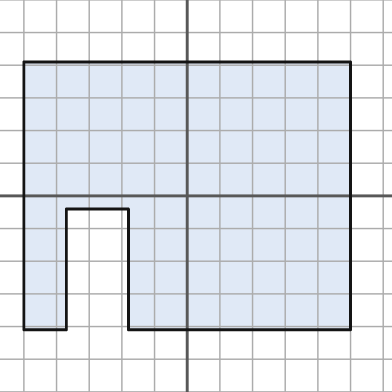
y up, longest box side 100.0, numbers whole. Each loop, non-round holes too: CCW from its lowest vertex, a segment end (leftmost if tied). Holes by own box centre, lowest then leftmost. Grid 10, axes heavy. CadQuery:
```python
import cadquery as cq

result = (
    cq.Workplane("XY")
    .moveTo(-50.0, -41.0)
    .lineTo(-37.0, -41.0)
    .lineTo(-37.0, -4.0)
    .lineTo(-18.0, -4.0)
    .lineTo(-18.0, -41.0)
    .lineTo(50.0, -41.0)
    .lineTo(50.0, 41.0)
    .lineTo(-50.0, 41.0)
    .close()
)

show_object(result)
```